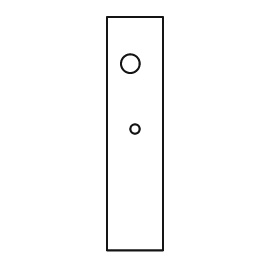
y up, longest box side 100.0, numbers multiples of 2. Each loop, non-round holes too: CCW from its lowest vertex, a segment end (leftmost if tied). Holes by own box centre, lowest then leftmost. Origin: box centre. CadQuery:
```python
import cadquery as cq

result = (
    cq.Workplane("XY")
    .moveTo(-12.0, -50.0)
    .lineTo(12.0, -50.0)
    .lineTo(12.0, 50.0)
    .lineTo(-12.0, 50.0)
    .close()
    .moveTo(0.0, 2.0)
    .circle(2.0)
    .moveTo(-2.0, 30.0)
    .circle(4.0)
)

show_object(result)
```